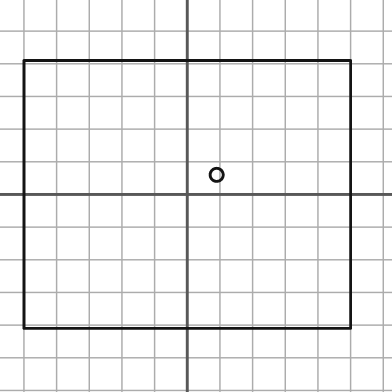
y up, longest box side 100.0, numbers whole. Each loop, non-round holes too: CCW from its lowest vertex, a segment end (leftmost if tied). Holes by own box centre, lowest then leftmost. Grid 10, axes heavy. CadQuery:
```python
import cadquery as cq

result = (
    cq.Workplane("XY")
    .moveTo(-50.0, -41.0)
    .lineTo(50.0, -41.0)
    .lineTo(50.0, 41.0)
    .lineTo(-50.0, 41.0)
    .close()
    .moveTo(9.0, 6.0)
    .circle(2.0)
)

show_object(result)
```